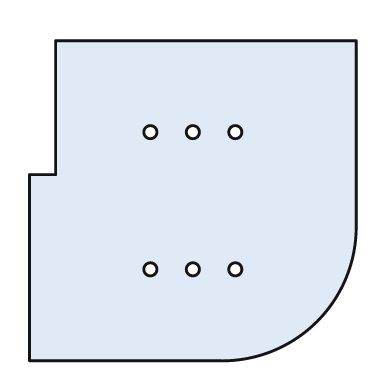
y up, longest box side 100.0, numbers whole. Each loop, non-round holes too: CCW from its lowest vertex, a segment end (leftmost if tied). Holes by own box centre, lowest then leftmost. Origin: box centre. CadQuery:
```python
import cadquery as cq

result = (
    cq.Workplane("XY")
    .moveTo(-50.0, -49.0)
    .lineTo(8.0, -49.0)
    .threePointArc((38.0, -37.0), (50.0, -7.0))
    .lineTo(50.0, 49.0)
    .lineTo(-42.0, 49.0)
    .lineTo(-42.0, 8.0)
    .lineTo(-50.0, 8.0)
    .close()
    .moveTo(-13.0, -21.0)
    .circle(2.0)
    .moveTo(0.0, -21.0)
    .circle(2.0)
    .moveTo(13.0, -21.0)
    .circle(2.0)
    .moveTo(-13.0, 21.0)
    .circle(2.0)
    .moveTo(0.0, 21.0)
    .circle(2.0)
    .moveTo(13.0, 21.0)
    .circle(2.0)
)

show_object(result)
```